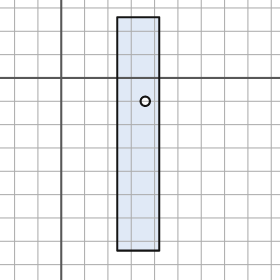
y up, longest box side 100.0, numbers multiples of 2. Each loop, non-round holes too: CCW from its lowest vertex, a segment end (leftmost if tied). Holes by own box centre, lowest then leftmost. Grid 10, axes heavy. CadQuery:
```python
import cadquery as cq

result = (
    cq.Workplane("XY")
    .moveTo(24.0, -74.0)
    .lineTo(42.0, -74.0)
    .lineTo(42.0, 26.0)
    .lineTo(24.0, 26.0)
    .close()
    .moveTo(36.0, -10.0)
    .circle(2.0)
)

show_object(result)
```